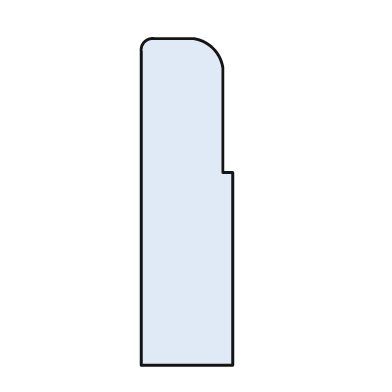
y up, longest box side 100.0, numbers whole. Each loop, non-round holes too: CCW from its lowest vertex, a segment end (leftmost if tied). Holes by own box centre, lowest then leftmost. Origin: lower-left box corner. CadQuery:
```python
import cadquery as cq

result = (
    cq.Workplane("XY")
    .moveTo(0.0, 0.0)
    .lineTo(28.0, 0.0)
    .lineTo(28.0, 59.0)
    .lineTo(25.0, 59.0)
    .lineTo(25.0, 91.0)
    .threePointArc((22.0, 97.0), (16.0, 100.0))
    .lineTo(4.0, 100.0)
    .threePointArc((1.0, 99.0), (0.0, 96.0))
    .close()
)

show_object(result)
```